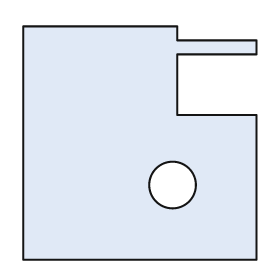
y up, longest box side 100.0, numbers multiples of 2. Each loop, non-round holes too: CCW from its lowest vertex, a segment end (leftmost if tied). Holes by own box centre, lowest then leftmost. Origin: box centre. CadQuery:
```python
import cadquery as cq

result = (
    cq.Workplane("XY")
    .moveTo(-50.0, -50.0)
    .lineTo(50.0, -50.0)
    .lineTo(50.0, 12.0)
    .lineTo(16.0, 12.0)
    .lineTo(16.0, 38.0)
    .lineTo(50.0, 38.0)
    .lineTo(50.0, 44.0)
    .lineTo(16.0, 44.0)
    .lineTo(16.0, 50.0)
    .lineTo(-50.0, 50.0)
    .close()
    .moveTo(14.0, -18.0)
    .circle(10.0)
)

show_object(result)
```